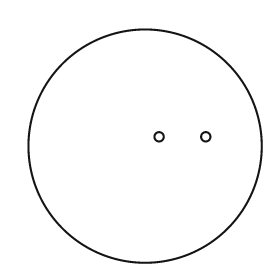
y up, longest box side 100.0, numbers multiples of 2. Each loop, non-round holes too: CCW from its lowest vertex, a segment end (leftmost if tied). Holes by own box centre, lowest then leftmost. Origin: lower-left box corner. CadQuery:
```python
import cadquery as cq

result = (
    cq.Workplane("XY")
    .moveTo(50.0, 50.0)
    .circle(50.0)
    .moveTo(56.0, 54.0)
    .circle(2.0)
    .moveTo(76.0, 54.0)
    .circle(2.0)
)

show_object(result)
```